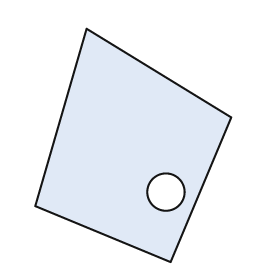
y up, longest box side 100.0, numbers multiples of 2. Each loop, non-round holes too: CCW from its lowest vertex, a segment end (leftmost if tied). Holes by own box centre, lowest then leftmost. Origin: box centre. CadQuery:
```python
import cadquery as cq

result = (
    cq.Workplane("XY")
    .moveTo(16.0, -50.0)
    .lineTo(42.0, 12.0)
    .lineTo(-20.0, 50.0)
    .lineTo(-42.0, -26.0)
    .close()
    .moveTo(14.0, -20.0)
    .circle(8.0)
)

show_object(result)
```